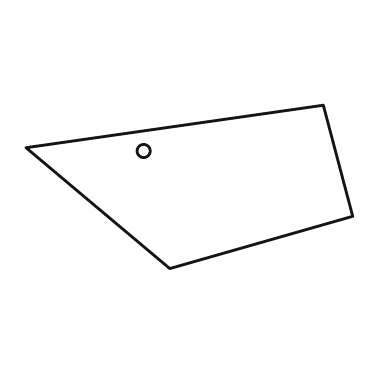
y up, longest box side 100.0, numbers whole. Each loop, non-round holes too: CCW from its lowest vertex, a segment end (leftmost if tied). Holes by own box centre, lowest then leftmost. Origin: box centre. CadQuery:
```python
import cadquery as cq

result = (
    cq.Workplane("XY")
    .moveTo(-6.0, -25.0)
    .lineTo(50.0, -9.0)
    .lineTo(41.0, 25.0)
    .lineTo(-50.0, 12.0)
    .close()
    .moveTo(-14.0, 11.0)
    .circle(2.0)
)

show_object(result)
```